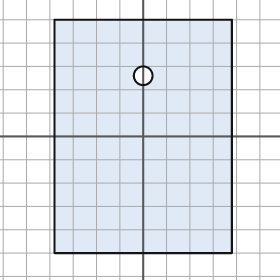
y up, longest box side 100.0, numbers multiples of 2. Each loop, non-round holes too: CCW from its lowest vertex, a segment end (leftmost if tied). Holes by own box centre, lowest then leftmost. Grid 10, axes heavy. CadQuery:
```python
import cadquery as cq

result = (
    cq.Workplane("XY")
    .moveTo(-38.0, -50.0)
    .lineTo(38.0, -50.0)
    .lineTo(38.0, 50.0)
    .lineTo(-38.0, 50.0)
    .close()
    .moveTo(0.0, 26.0)
    .circle(4.0)
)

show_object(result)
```